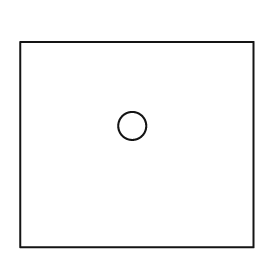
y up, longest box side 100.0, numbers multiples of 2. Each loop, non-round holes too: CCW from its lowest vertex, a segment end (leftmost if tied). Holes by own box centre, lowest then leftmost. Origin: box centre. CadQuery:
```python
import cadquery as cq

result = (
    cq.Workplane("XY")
    .moveTo(-50.0, -44.0)
    .lineTo(50.0, -44.0)
    .lineTo(50.0, 44.0)
    .lineTo(-50.0, 44.0)
    .close()
    .moveTo(-2.0, 8.0)
    .circle(6.0)
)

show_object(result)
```